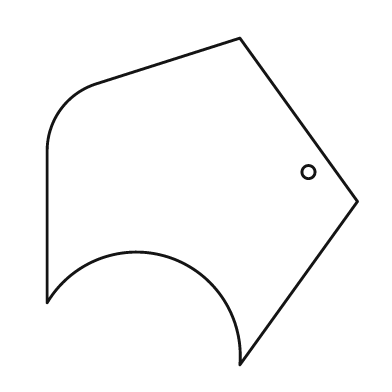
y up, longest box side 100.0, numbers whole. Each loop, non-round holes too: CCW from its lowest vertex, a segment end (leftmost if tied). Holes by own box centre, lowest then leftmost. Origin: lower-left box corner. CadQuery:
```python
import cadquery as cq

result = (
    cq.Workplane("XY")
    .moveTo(59.0, 0.0)
    .lineTo(95.0, 50.0)
    .lineTo(59.0, 100.0)
    .lineTo(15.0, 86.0)
    .threePointArc((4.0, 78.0), (0.0, 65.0))
    .lineTo(0.0, 19.0)
    .threePointArc((37.0, 33.0), (59.0, 0.0))
    .close()
    .moveTo(80.0, 59.0)
    .circle(2.0)
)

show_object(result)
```